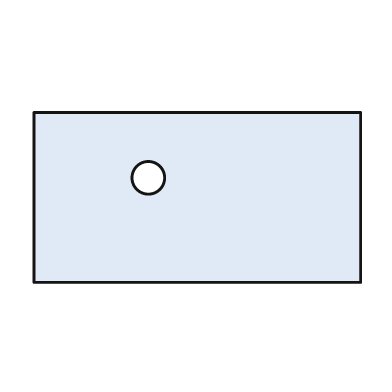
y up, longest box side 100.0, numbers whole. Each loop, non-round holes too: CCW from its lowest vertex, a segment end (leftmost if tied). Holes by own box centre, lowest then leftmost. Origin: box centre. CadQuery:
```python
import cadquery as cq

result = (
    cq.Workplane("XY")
    .moveTo(-50.0, -26.0)
    .lineTo(50.0, -26.0)
    .lineTo(50.0, 26.0)
    .lineTo(-50.0, 26.0)
    .close()
    .moveTo(-15.0, 6.0)
    .circle(5.0)
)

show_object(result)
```